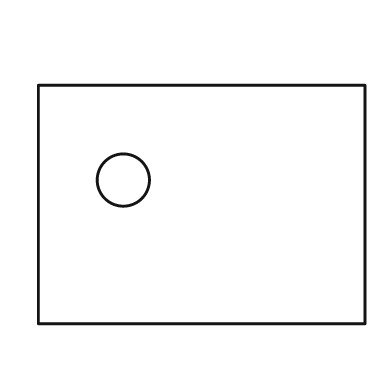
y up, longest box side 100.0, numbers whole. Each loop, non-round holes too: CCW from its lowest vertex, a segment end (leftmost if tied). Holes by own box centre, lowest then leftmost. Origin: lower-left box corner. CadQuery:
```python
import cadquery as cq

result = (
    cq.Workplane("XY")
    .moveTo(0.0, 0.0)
    .lineTo(100.0, 0.0)
    .lineTo(100.0, 73.0)
    .lineTo(0.0, 73.0)
    .close()
    .moveTo(26.0, 44.0)
    .circle(8.0)
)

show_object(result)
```